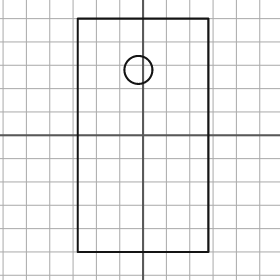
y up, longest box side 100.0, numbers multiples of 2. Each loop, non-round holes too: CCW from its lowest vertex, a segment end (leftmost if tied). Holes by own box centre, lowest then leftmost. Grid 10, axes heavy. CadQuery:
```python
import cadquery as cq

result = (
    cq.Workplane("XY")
    .moveTo(-28.0, -50.0)
    .lineTo(28.0, -50.0)
    .lineTo(28.0, 50.0)
    .lineTo(-28.0, 50.0)
    .close()
    .moveTo(-2.0, 28.0)
    .circle(6.0)
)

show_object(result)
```